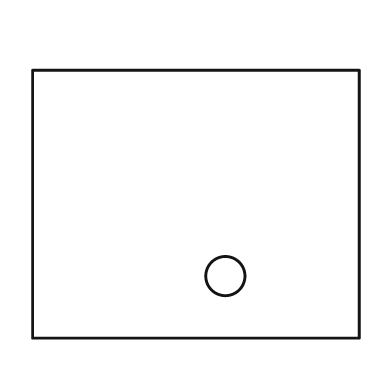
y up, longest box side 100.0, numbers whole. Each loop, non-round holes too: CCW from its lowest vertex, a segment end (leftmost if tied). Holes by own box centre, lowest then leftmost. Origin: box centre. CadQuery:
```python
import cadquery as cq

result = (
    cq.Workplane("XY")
    .moveTo(-50.0, -41.0)
    .lineTo(50.0, -41.0)
    .lineTo(50.0, 41.0)
    .lineTo(-50.0, 41.0)
    .close()
    .moveTo(9.0, -22.0)
    .circle(6.0)
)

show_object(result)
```